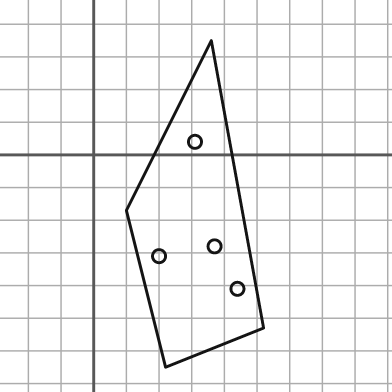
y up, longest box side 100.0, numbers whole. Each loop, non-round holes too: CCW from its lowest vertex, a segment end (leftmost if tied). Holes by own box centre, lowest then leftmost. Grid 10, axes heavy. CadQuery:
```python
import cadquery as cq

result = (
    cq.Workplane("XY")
    .moveTo(22.0, -65.0)
    .lineTo(52.0, -53.0)
    .lineTo(36.0, 35.0)
    .lineTo(10.0, -17.0)
    .close()
    .moveTo(44.0, -41.0)
    .circle(2.0)
    .moveTo(20.0, -31.0)
    .circle(2.0)
    .moveTo(37.0, -28.0)
    .circle(2.0)
    .moveTo(31.0, 4.0)
    .circle(2.0)
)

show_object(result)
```